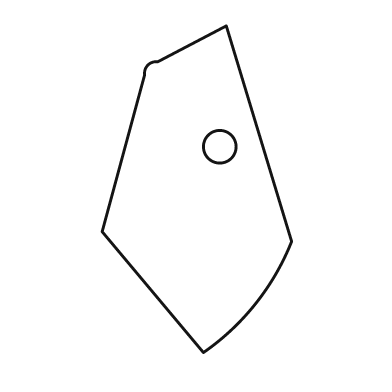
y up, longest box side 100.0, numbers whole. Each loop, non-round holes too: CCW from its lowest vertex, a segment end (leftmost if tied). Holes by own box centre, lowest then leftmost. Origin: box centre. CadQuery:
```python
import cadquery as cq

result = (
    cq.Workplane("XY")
    .moveTo(2.0, -50.0)
    .threePointArc((18.0, -35.0), (29.0, -16.0))
    .lineTo(9.0, 50.0)
    .lineTo(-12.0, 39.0)
    .threePointArc((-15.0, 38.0), (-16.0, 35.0))
    .lineTo(-29.0, -13.0)
    .close()
    .moveTo(7.0, 13.0)
    .circle(5.0)
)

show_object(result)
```